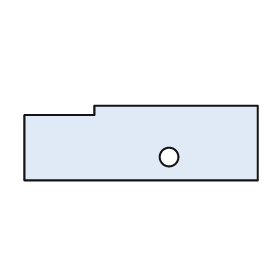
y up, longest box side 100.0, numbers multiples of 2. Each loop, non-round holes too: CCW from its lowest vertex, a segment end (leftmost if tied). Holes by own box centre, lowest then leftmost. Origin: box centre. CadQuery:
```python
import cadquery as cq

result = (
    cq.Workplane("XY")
    .moveTo(-50.0, -16.0)
    .lineTo(50.0, -16.0)
    .lineTo(50.0, 16.0)
    .lineTo(-20.0, 16.0)
    .lineTo(-20.0, 12.0)
    .lineTo(-50.0, 12.0)
    .close()
    .moveTo(12.0, -6.0)
    .circle(4.0)
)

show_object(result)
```